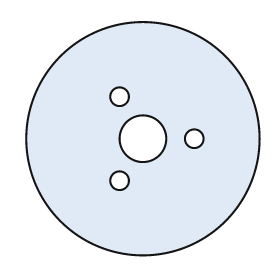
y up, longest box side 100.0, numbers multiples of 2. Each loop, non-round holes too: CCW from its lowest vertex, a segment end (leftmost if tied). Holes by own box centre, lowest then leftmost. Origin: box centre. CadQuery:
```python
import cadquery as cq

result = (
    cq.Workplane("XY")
    .moveTo(0.0, 0.0)
    .circle(50.0)
    .moveTo(-10.0, -18.0)
    .circle(4.0)
    .moveTo(0.0, 0.0)
    .circle(10.0)
    .moveTo(22.0, 0.0)
    .circle(4.0)
    .moveTo(-10.0, 18.0)
    .circle(4.0)
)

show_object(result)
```